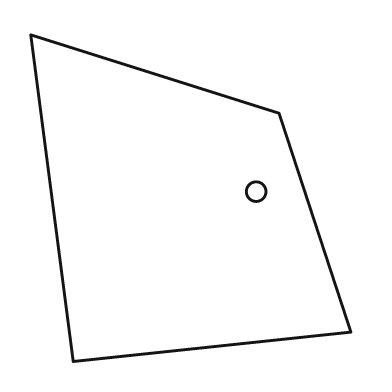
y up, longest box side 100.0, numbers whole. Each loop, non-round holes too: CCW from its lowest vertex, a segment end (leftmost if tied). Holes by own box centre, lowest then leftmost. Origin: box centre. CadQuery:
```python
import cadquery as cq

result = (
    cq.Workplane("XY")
    .moveTo(-36.0, -50.0)
    .lineTo(49.0, -41.0)
    .lineTo(27.0, 26.0)
    .lineTo(-49.0, 50.0)
    .close()
    .moveTo(20.0, 2.0)
    .circle(3.0)
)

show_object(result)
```